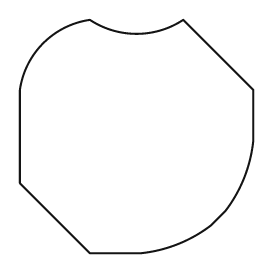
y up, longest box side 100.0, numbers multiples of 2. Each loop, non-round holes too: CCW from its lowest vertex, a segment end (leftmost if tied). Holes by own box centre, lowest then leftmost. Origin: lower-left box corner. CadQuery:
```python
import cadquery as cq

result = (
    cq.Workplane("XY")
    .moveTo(30.0, 0.0)
    .lineTo(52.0, 0.0)
    .threePointArc((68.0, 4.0), (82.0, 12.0))
    .lineTo(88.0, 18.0)
    .threePointArc((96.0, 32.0), (100.0, 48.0))
    .lineTo(100.0, 70.0)
    .lineTo(70.0, 100.0)
    .threePointArc((50.0, 94.0), (30.0, 100.0))
    .threePointArc((10.0, 90.0), (0.0, 70.0))
    .lineTo(0.0, 30.0)
    .close()
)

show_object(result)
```